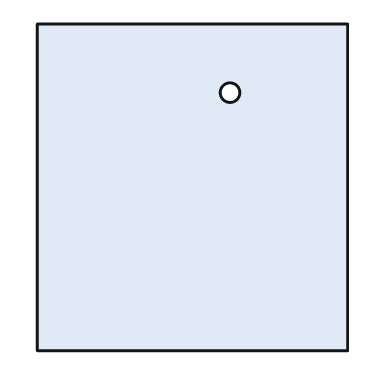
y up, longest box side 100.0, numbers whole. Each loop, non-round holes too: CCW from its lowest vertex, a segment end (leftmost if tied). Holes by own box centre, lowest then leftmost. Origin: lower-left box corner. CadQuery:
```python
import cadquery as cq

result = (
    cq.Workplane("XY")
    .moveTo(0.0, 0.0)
    .lineTo(95.0, 0.0)
    .lineTo(95.0, 100.0)
    .lineTo(0.0, 100.0)
    .close()
    .moveTo(59.0, 79.0)
    .circle(3.0)
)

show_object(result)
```